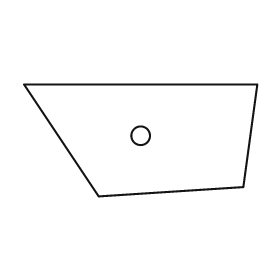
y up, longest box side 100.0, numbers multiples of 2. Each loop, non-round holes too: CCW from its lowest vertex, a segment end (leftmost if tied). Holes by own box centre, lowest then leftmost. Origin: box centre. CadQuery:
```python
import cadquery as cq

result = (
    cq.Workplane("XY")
    .moveTo(-18.0, -24.0)
    .lineTo(44.0, -20.0)
    .lineTo(50.0, 24.0)
    .lineTo(-50.0, 24.0)
    .close()
    .moveTo(0.0, 2.0)
    .circle(4.0)
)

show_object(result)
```